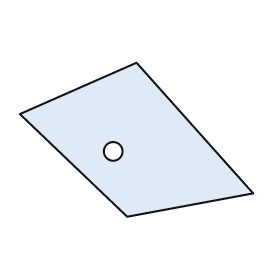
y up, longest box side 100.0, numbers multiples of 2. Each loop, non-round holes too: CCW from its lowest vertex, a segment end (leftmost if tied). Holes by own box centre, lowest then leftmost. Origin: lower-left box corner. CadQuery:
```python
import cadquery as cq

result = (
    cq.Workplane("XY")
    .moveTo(46.0, 0.0)
    .lineTo(100.0, 10.0)
    .lineTo(50.0, 66.0)
    .lineTo(0.0, 44.0)
    .close()
    .moveTo(40.0, 28.0)
    .circle(4.0)
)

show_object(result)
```